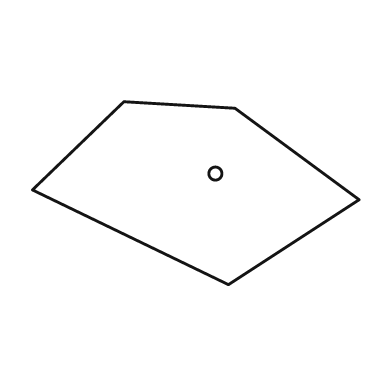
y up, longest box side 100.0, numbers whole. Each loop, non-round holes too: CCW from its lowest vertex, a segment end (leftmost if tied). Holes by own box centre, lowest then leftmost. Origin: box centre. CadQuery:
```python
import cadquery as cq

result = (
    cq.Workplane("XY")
    .moveTo(10.0, -28.0)
    .lineTo(50.0, -2.0)
    .lineTo(12.0, 26.0)
    .lineTo(-22.0, 28.0)
    .lineTo(-50.0, 1.0)
    .close()
    .moveTo(6.0, 6.0)
    .circle(2.0)
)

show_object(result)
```